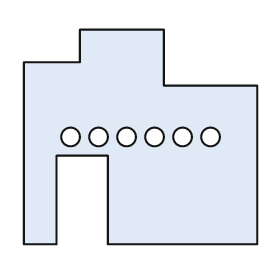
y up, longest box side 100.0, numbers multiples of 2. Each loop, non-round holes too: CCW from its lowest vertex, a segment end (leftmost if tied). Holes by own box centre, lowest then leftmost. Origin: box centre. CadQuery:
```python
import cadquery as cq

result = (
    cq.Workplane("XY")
    .moveTo(-50.0, -46.0)
    .lineTo(-36.0, -46.0)
    .lineTo(-36.0, -8.0)
    .lineTo(-14.0, -8.0)
    .lineTo(-14.0, -46.0)
    .lineTo(50.0, -46.0)
    .lineTo(50.0, 22.0)
    .lineTo(10.0, 22.0)
    .lineTo(10.0, 46.0)
    .lineTo(-26.0, 46.0)
    .lineTo(-26.0, 32.0)
    .lineTo(-50.0, 32.0)
    .close()
    .moveTo(-30.0, 0.0)
    .circle(4.0)
    .moveTo(-18.0, 0.0)
    .circle(4.0)
    .moveTo(-6.0, 0.0)
    .circle(4.0)
    .moveTo(6.0, 0.0)
    .circle(4.0)
    .moveTo(18.0, 0.0)
    .circle(4.0)
    .moveTo(30.0, 0.0)
    .circle(4.0)
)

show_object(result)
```